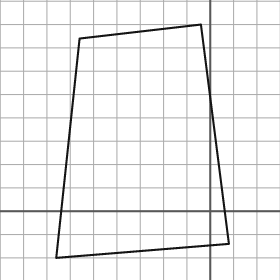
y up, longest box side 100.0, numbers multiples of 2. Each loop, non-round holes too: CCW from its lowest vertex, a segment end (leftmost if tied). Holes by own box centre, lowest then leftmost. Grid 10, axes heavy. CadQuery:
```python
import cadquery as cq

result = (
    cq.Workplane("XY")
    .moveTo(-66.0, -20.0)
    .lineTo(8.0, -14.0)
    .lineTo(-4.0, 80.0)
    .lineTo(-56.0, 74.0)
    .close()
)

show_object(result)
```